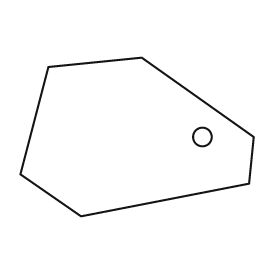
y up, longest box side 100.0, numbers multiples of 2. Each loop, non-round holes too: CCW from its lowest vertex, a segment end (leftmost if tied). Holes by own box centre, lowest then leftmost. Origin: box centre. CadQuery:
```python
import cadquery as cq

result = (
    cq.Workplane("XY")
    .moveTo(-24.0, -34.0)
    .lineTo(48.0, -20.0)
    .lineTo(50.0, 0.0)
    .lineTo(2.0, 34.0)
    .lineTo(-38.0, 30.0)
    .lineTo(-50.0, -16.0)
    .close()
    .moveTo(28.0, 0.0)
    .circle(4.0)
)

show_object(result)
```